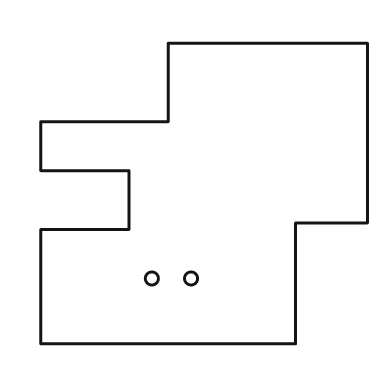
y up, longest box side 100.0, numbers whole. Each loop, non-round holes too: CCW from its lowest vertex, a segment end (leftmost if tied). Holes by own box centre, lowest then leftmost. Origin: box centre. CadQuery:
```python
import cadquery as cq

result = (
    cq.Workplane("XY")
    .moveTo(-50.0, -46.0)
    .lineTo(28.0, -46.0)
    .lineTo(28.0, -9.0)
    .lineTo(50.0, -9.0)
    .lineTo(50.0, 46.0)
    .lineTo(-11.0, 46.0)
    .lineTo(-11.0, 22.0)
    .lineTo(-50.0, 22.0)
    .lineTo(-50.0, 7.0)
    .lineTo(-23.0, 7.0)
    .lineTo(-23.0, -11.0)
    .lineTo(-50.0, -11.0)
    .close()
    .moveTo(-16.0, -26.0)
    .circle(2.0)
    .moveTo(-4.0, -26.0)
    .circle(2.0)
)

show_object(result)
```